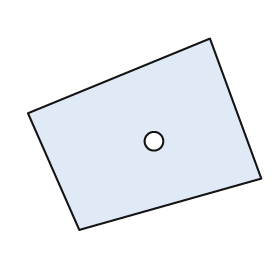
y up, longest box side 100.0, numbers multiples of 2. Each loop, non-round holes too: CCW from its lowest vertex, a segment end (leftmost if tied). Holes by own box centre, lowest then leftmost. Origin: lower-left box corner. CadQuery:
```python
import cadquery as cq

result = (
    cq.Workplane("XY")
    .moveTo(22.0, 0.0)
    .lineTo(100.0, 22.0)
    .lineTo(78.0, 82.0)
    .lineTo(0.0, 50.0)
    .close()
    .moveTo(54.0, 38.0)
    .circle(4.0)
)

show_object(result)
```